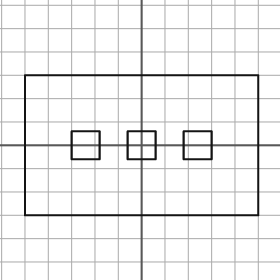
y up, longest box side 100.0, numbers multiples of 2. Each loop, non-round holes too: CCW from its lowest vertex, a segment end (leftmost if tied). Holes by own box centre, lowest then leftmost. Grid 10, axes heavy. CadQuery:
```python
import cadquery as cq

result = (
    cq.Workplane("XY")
    .moveTo(-50.0, -30.0)
    .lineTo(50.0, -30.0)
    .lineTo(50.0, 30.0)
    .lineTo(-50.0, 30.0)
    .close()
    .moveTo(-30.0, -6.0)
    .lineTo(-18.0, -6.0)
    .lineTo(-18.0, 6.0)
    .lineTo(-30.0, 6.0)
    .close()
    .moveTo(-6.0, -6.0)
    .lineTo(6.0, -6.0)
    .lineTo(6.0, 6.0)
    .lineTo(-6.0, 6.0)
    .close()
    .moveTo(18.0, -6.0)
    .lineTo(30.0, -6.0)
    .lineTo(30.0, 6.0)
    .lineTo(18.0, 6.0)
    .close()
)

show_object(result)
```